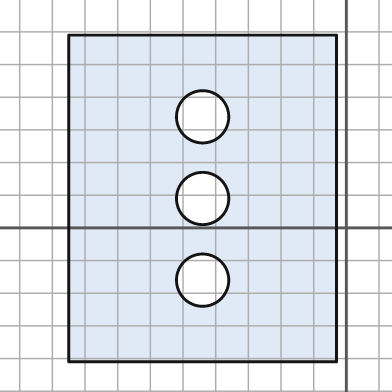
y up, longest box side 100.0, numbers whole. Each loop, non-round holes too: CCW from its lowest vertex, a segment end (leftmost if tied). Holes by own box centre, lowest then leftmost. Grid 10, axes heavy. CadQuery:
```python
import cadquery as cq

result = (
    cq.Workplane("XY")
    .moveTo(-85.0, -41.0)
    .lineTo(-3.0, -41.0)
    .lineTo(-3.0, 59.0)
    .lineTo(-85.0, 59.0)
    .close()
    .moveTo(-44.0, -16.0)
    .circle(8.0)
    .moveTo(-44.0, 9.0)
    .circle(8.0)
    .moveTo(-44.0, 34.0)
    .circle(8.0)
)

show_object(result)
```